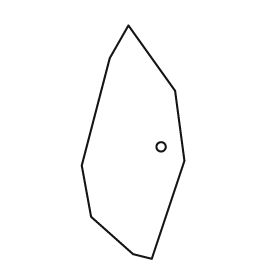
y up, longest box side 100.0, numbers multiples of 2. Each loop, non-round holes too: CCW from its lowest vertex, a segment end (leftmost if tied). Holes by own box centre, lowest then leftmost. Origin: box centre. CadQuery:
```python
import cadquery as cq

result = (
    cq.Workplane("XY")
    .moveTo(8.0, -50.0)
    .lineTo(22.0, -8.0)
    .lineTo(18.0, 22.0)
    .lineTo(-2.0, 50.0)
    .lineTo(-10.0, 36.0)
    .lineTo(-22.0, -10.0)
    .lineTo(-18.0, -32.0)
    .lineTo(0.0, -48.0)
    .close()
    .moveTo(12.0, -2.0)
    .circle(2.0)
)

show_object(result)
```